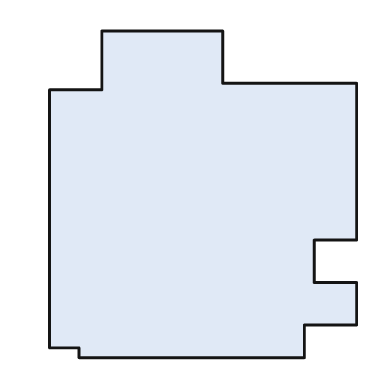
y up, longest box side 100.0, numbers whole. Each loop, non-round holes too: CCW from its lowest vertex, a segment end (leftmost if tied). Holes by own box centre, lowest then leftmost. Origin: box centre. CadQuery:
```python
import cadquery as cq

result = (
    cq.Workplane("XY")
    .moveTo(-38.0, -50.0)
    .lineTo(31.0, -50.0)
    .lineTo(31.0, -40.0)
    .lineTo(47.0, -40.0)
    .lineTo(47.0, -27.0)
    .lineTo(34.0, -27.0)
    .lineTo(34.0, -14.0)
    .lineTo(47.0, -14.0)
    .lineTo(47.0, 34.0)
    .lineTo(6.0, 34.0)
    .lineTo(6.0, 50.0)
    .lineTo(-31.0, 50.0)
    .lineTo(-31.0, 32.0)
    .lineTo(-47.0, 32.0)
    .lineTo(-47.0, -47.0)
    .lineTo(-38.0, -47.0)
    .close()
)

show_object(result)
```